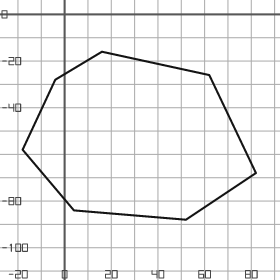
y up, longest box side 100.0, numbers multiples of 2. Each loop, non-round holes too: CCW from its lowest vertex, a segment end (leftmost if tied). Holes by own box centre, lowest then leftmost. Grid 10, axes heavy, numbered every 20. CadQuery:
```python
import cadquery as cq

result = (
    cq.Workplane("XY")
    .moveTo(52.0, -88.0)
    .lineTo(82.0, -68.0)
    .lineTo(62.0, -26.0)
    .lineTo(16.0, -16.0)
    .lineTo(-4.0, -28.0)
    .lineTo(-18.0, -58.0)
    .lineTo(4.0, -84.0)
    .close()
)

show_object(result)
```